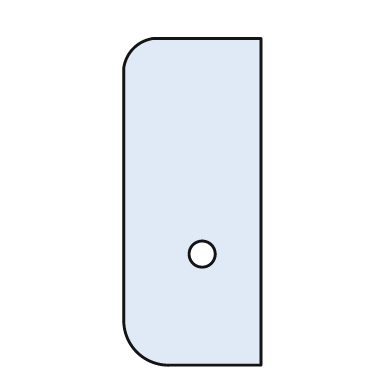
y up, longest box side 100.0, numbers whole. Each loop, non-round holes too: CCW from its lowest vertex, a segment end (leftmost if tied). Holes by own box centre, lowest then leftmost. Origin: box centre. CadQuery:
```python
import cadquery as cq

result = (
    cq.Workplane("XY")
    .moveTo(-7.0, -50.0)
    .lineTo(21.0, -50.0)
    .lineTo(21.0, 50.0)
    .lineTo(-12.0, 50.0)
    .threePointArc((-18.0, 47.0), (-21.0, 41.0))
    .lineTo(-21.0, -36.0)
    .threePointArc((-17.0, -46.0), (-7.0, -50.0))
    .close()
    .moveTo(3.0, -16.0)
    .circle(4.0)
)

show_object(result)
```